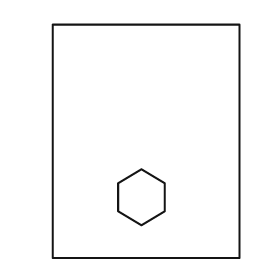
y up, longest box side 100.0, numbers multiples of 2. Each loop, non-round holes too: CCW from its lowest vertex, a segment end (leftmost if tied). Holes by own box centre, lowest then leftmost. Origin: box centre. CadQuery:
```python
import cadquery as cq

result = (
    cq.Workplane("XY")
    .moveTo(-40.0, -50.0)
    .lineTo(40.0, -50.0)
    .lineTo(40.0, 50.0)
    .lineTo(-40.0, 50.0)
    .close()
    .moveTo(-2.0, -36.0)
    .lineTo(8.0, -30.0)
    .lineTo(8.0, -18.0)
    .lineTo(-2.0, -12.0)
    .lineTo(-12.0, -18.0)
    .lineTo(-12.0, -30.0)
    .close()
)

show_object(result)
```